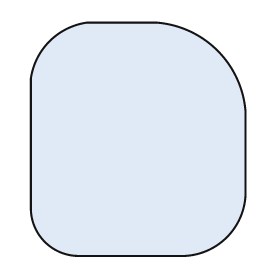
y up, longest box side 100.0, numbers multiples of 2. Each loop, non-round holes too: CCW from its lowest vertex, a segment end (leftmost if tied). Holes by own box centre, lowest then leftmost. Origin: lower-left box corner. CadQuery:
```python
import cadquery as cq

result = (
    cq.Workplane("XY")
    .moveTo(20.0, 0.0)
    .lineTo(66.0, 0.0)
    .threePointArc((84.0, 8.0), (92.0, 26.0))
    .lineTo(92.0, 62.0)
    .threePointArc((80.0, 88.0), (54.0, 100.0))
    .lineTo(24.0, 100.0)
    .threePointArc((8.0, 92.0), (0.0, 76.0))
    .lineTo(0.0, 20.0)
    .threePointArc((6.0, 6.0), (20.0, 0.0))
    .close()
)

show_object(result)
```